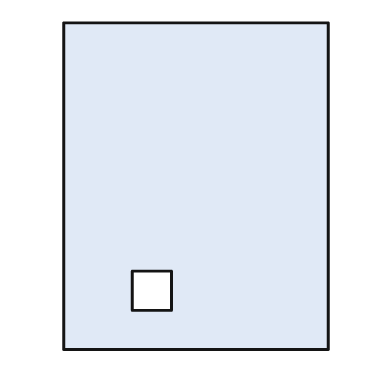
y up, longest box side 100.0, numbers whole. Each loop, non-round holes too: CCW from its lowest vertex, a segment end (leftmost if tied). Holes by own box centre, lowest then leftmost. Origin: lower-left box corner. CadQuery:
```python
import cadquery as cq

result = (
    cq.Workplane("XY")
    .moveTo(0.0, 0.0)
    .lineTo(81.0, 0.0)
    .lineTo(81.0, 100.0)
    .lineTo(0.0, 100.0)
    .close()
    .moveTo(21.0, 12.0)
    .lineTo(33.0, 12.0)
    .lineTo(33.0, 24.0)
    .lineTo(21.0, 24.0)
    .close()
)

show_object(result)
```